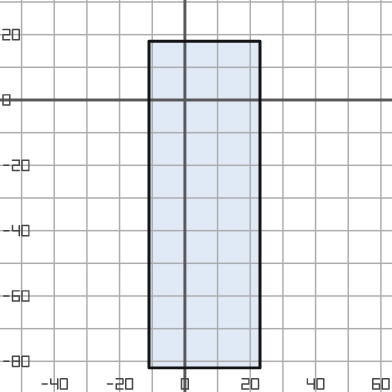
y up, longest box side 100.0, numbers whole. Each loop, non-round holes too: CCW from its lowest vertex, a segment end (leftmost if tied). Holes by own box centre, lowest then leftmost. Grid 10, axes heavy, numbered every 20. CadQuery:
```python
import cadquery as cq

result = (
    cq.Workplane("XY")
    .moveTo(-11.0, -82.0)
    .lineTo(23.0, -82.0)
    .lineTo(23.0, 18.0)
    .lineTo(-11.0, 18.0)
    .close()
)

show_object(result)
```